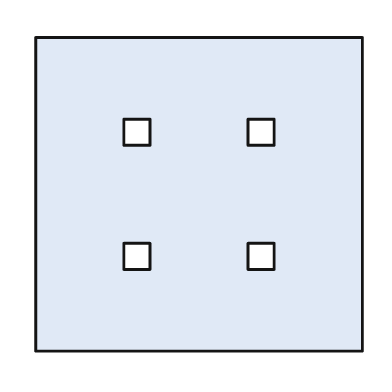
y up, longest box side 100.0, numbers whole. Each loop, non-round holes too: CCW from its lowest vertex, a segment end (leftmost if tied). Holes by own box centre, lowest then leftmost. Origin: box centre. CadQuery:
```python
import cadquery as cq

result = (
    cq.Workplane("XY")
    .moveTo(-50.0, -48.0)
    .lineTo(50.0, -48.0)
    .lineTo(50.0, 48.0)
    .lineTo(-50.0, 48.0)
    .close()
    .moveTo(-23.0, -23.0)
    .lineTo(-15.0, -23.0)
    .lineTo(-15.0, -15.0)
    .lineTo(-23.0, -15.0)
    .close()
    .moveTo(15.0, -23.0)
    .lineTo(23.0, -23.0)
    .lineTo(23.0, -15.0)
    .lineTo(15.0, -15.0)
    .close()
    .moveTo(-23.0, 15.0)
    .lineTo(-15.0, 15.0)
    .lineTo(-15.0, 23.0)
    .lineTo(-23.0, 23.0)
    .close()
    .moveTo(15.0, 15.0)
    .lineTo(23.0, 15.0)
    .lineTo(23.0, 23.0)
    .lineTo(15.0, 23.0)
    .close()
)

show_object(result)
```